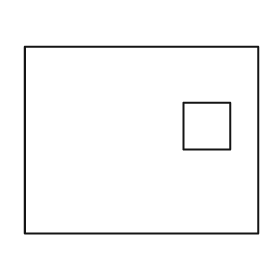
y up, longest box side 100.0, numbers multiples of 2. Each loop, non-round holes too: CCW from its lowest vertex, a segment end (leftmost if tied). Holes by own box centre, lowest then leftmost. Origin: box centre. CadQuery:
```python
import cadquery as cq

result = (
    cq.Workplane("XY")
    .moveTo(-50.0, -40.0)
    .lineTo(50.0, -40.0)
    .lineTo(50.0, 40.0)
    .lineTo(-50.0, 40.0)
    .close()
    .moveTo(18.0, -4.0)
    .lineTo(38.0, -4.0)
    .lineTo(38.0, 16.0)
    .lineTo(18.0, 16.0)
    .close()
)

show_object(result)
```